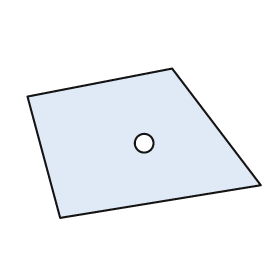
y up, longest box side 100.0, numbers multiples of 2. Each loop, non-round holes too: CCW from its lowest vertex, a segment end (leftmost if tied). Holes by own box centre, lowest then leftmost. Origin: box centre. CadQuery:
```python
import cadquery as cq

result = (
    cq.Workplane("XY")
    .moveTo(-36.0, -32.0)
    .lineTo(50.0, -18.0)
    .lineTo(12.0, 32.0)
    .lineTo(-50.0, 20.0)
    .close()
    .moveTo(0.0, 0.0)
    .circle(4.0)
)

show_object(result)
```